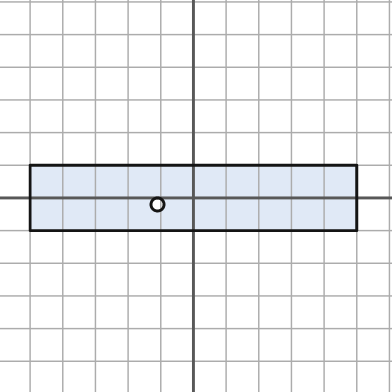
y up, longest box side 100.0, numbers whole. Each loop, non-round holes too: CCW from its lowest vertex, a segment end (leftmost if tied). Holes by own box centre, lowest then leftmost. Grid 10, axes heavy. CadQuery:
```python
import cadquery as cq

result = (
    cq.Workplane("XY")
    .moveTo(-50.0, -10.0)
    .lineTo(50.0, -10.0)
    .lineTo(50.0, 10.0)
    .lineTo(-50.0, 10.0)
    .close()
    .moveTo(-11.0, -2.0)
    .circle(2.0)
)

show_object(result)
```